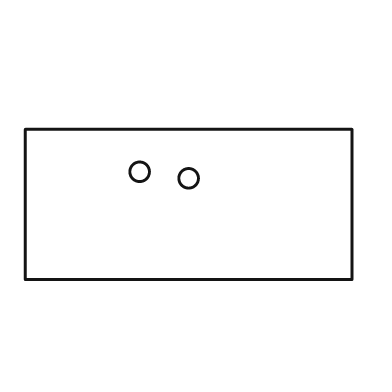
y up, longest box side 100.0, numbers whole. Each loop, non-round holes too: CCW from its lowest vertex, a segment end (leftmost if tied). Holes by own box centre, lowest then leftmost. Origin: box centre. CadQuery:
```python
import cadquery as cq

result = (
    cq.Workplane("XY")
    .moveTo(-50.0, -23.0)
    .lineTo(50.0, -23.0)
    .lineTo(50.0, 23.0)
    .lineTo(-50.0, 23.0)
    .close()
    .moveTo(0.0, 8.0)
    .circle(3.0)
    .moveTo(-15.0, 10.0)
    .circle(3.0)
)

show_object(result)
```